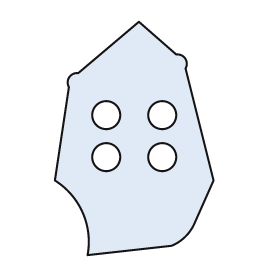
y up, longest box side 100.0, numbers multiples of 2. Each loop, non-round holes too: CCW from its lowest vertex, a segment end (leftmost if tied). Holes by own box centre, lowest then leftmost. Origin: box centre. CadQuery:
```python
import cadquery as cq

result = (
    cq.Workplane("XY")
    .moveTo(-20.0, -50.0)
    .lineTo(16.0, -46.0)
    .threePointArc((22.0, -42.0), (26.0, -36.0))
    .lineTo(34.0, -18.0)
    .lineTo(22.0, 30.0)
    .threePointArc((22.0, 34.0), (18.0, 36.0))
    .lineTo(2.0, 50.0)
    .lineTo(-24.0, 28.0)
    .threePointArc((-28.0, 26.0), (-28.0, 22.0))
    .lineTo(-34.0, -18.0)
    .threePointArc((-22.0, -32.0), (-20.0, -50.0))
    .close()
    .moveTo(-12.0, -8.0)
    .circle(6.0)
    .moveTo(12.0, -8.0)
    .circle(6.0)
    .moveTo(-12.0, 10.0)
    .circle(6.0)
    .moveTo(12.0, 10.0)
    .circle(6.0)
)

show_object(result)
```